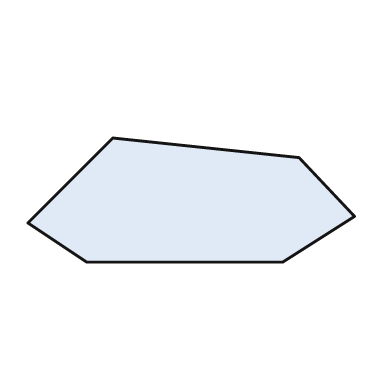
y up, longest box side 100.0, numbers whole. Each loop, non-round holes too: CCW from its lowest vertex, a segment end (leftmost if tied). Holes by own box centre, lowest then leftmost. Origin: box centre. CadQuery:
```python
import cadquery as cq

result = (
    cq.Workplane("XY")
    .moveTo(-32.0, -19.0)
    .lineTo(28.0, -19.0)
    .lineTo(50.0, -5.0)
    .lineTo(33.0, 13.0)
    .lineTo(-24.0, 19.0)
    .lineTo(-50.0, -7.0)
    .close()
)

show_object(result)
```